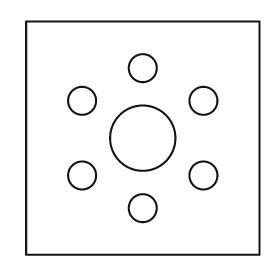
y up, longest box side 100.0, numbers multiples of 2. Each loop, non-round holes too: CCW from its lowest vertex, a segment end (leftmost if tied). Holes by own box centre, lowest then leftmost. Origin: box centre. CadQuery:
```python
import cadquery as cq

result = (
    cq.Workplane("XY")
    .moveTo(-50.0, -50.0)
    .lineTo(50.0, -50.0)
    .lineTo(50.0, 50.0)
    .lineTo(-50.0, 50.0)
    .close()
    .moveTo(0.0, -30.0)
    .circle(6.0)
    .moveTo(-26.0, -16.0)
    .circle(6.0)
    .moveTo(26.0, -16.0)
    .circle(6.0)
    .moveTo(0.0, 0.0)
    .circle(14.0)
    .moveTo(-26.0, 16.0)
    .circle(6.0)
    .moveTo(26.0, 16.0)
    .circle(6.0)
    .moveTo(0.0, 30.0)
    .circle(6.0)
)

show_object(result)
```